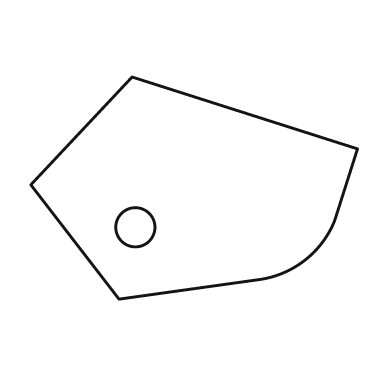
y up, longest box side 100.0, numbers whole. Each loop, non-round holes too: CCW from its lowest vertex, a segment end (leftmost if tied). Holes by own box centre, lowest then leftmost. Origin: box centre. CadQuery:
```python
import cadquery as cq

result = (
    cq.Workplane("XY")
    .moveTo(-23.0, -34.0)
    .lineTo(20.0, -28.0)
    .threePointArc((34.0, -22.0), (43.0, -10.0))
    .lineTo(50.0, 12.0)
    .lineTo(-19.0, 34.0)
    .lineTo(-50.0, 1.0)
    .close()
    .moveTo(-18.0, -12.0)
    .circle(6.0)
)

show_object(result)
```